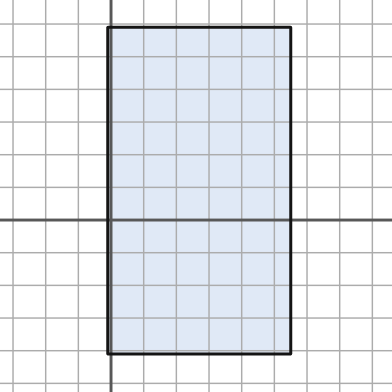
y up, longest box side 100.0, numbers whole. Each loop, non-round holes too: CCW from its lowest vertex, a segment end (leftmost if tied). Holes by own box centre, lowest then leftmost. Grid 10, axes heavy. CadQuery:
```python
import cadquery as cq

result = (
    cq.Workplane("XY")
    .moveTo(-1.0, -41.0)
    .lineTo(55.0, -41.0)
    .lineTo(55.0, 59.0)
    .lineTo(-1.0, 59.0)
    .close()
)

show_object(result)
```